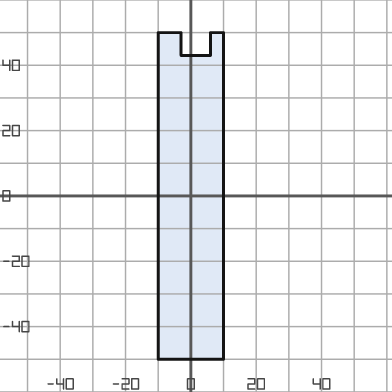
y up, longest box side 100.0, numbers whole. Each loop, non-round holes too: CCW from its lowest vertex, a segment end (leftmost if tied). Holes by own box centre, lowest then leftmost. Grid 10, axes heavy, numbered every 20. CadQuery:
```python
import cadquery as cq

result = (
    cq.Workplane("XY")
    .moveTo(-10.0, -50.0)
    .lineTo(10.0, -50.0)
    .lineTo(10.0, 50.0)
    .lineTo(6.0, 50.0)
    .lineTo(6.0, 43.0)
    .lineTo(-3.0, 43.0)
    .lineTo(-3.0, 50.0)
    .lineTo(-10.0, 50.0)
    .close()
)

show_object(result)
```